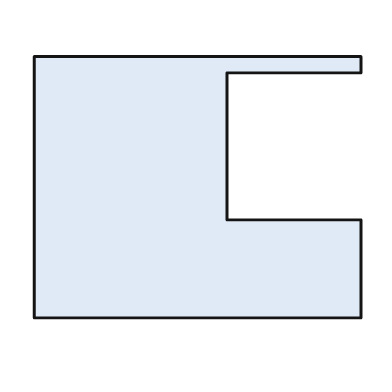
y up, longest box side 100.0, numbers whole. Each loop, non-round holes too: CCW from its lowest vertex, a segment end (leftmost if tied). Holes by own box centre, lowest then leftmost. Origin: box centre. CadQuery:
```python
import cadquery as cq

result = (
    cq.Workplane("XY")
    .moveTo(-50.0, -40.0)
    .lineTo(50.0, -40.0)
    .lineTo(50.0, -10.0)
    .lineTo(9.0, -10.0)
    .lineTo(9.0, 35.0)
    .lineTo(50.0, 35.0)
    .lineTo(50.0, 40.0)
    .lineTo(-50.0, 40.0)
    .close()
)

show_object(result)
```